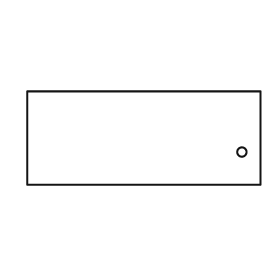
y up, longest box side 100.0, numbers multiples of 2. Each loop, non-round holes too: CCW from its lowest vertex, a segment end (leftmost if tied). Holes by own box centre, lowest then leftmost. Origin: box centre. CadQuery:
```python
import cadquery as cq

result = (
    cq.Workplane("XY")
    .moveTo(-50.0, -20.0)
    .lineTo(50.0, -20.0)
    .lineTo(50.0, 20.0)
    .lineTo(-50.0, 20.0)
    .close()
    .moveTo(42.0, -6.0)
    .circle(2.0)
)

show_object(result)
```